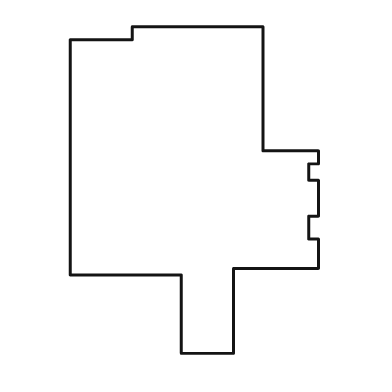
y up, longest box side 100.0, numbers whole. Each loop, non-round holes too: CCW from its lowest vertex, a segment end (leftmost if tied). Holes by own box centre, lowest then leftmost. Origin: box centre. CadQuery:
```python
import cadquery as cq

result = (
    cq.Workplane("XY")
    .moveTo(-4.0, -50.0)
    .lineTo(12.0, -50.0)
    .lineTo(12.0, -24.0)
    .lineTo(38.0, -24.0)
    .lineTo(38.0, -15.0)
    .lineTo(35.0, -15.0)
    .lineTo(35.0, -8.0)
    .lineTo(38.0, -8.0)
    .lineTo(38.0, 3.0)
    .lineTo(35.0, 3.0)
    .lineTo(35.0, 8.0)
    .lineTo(38.0, 8.0)
    .lineTo(38.0, 12.0)
    .lineTo(21.0, 12.0)
    .lineTo(21.0, 50.0)
    .lineTo(-19.0, 50.0)
    .lineTo(-19.0, 46.0)
    .lineTo(-38.0, 46.0)
    .lineTo(-38.0, -26.0)
    .lineTo(-4.0, -26.0)
    .close()
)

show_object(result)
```